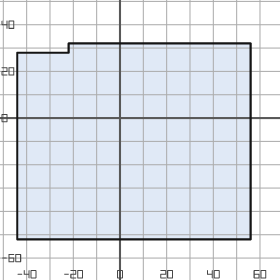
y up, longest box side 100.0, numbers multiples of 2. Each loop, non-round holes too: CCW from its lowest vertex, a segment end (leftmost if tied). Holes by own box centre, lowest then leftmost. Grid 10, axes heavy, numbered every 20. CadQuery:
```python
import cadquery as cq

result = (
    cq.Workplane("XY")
    .moveTo(-44.0, -52.0)
    .lineTo(56.0, -52.0)
    .lineTo(56.0, 32.0)
    .lineTo(-22.0, 32.0)
    .lineTo(-22.0, 28.0)
    .lineTo(-44.0, 28.0)
    .close()
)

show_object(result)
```